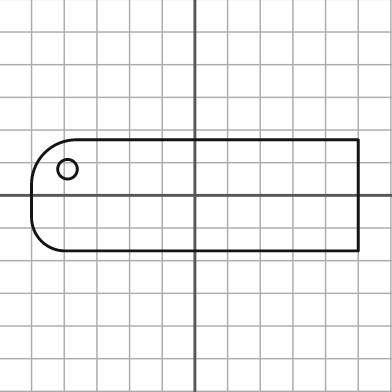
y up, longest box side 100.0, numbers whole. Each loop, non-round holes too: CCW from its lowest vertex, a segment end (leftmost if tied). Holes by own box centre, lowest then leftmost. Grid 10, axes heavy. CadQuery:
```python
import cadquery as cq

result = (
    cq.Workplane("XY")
    .moveTo(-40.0, -17.0)
    .lineTo(50.0, -17.0)
    .lineTo(50.0, 17.0)
    .lineTo(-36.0, 17.0)
    .threePointArc((-46.0, 13.0), (-50.0, 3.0))
    .lineTo(-50.0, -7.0)
    .threePointArc((-47.0, -14.0), (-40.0, -17.0))
    .close()
    .moveTo(-39.0, 8.0)
    .circle(3.0)
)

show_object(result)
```